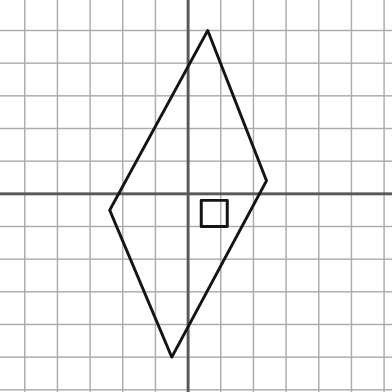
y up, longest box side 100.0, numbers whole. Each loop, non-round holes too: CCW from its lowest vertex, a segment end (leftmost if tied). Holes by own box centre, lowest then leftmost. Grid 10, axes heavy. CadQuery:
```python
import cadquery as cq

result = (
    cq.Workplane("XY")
    .moveTo(-5.0, -50.0)
    .lineTo(24.0, 4.0)
    .lineTo(6.0, 50.0)
    .lineTo(-24.0, -5.0)
    .close()
    .moveTo(4.0, -10.0)
    .lineTo(12.0, -10.0)
    .lineTo(12.0, -2.0)
    .lineTo(4.0, -2.0)
    .close()
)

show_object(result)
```